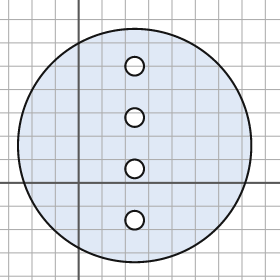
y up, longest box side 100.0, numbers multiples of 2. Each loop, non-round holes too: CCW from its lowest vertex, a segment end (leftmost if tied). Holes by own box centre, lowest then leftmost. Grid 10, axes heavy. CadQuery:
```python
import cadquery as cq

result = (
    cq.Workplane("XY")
    .moveTo(24.0, 16.0)
    .circle(50.0)
    .moveTo(24.0, -16.0)
    .circle(4.0)
    .moveTo(24.0, 6.0)
    .circle(4.0)
    .moveTo(24.0, 28.0)
    .circle(4.0)
    .moveTo(24.0, 50.0)
    .circle(4.0)
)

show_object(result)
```